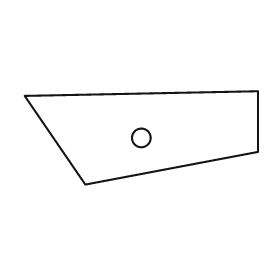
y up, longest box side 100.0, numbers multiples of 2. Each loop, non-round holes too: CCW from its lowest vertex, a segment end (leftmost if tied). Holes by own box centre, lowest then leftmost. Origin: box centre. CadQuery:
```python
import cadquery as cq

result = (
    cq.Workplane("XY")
    .moveTo(-24.0, -20.0)
    .lineTo(50.0, -6.0)
    .lineTo(50.0, 20.0)
    .lineTo(-50.0, 18.0)
    .close()
    .moveTo(0.0, 0.0)
    .circle(4.0)
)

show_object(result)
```